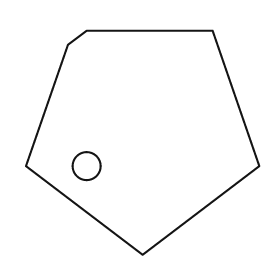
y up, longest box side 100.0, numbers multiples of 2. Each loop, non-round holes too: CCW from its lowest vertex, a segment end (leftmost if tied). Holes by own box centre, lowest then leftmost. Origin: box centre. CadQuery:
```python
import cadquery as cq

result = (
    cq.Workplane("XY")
    .moveTo(0.0, -48.0)
    .lineTo(50.0, -10.0)
    .lineTo(30.0, 48.0)
    .lineTo(-24.0, 48.0)
    .lineTo(-32.0, 42.0)
    .lineTo(-50.0, -10.0)
    .close()
    .moveTo(-24.0, -10.0)
    .circle(6.0)
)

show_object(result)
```